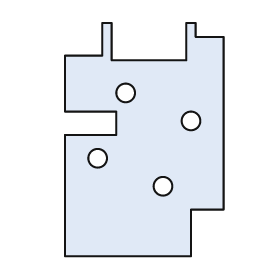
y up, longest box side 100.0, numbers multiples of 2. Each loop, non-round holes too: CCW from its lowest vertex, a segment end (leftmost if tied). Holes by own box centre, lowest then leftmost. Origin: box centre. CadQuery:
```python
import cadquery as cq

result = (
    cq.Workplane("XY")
    .moveTo(-34.0, -50.0)
    .lineTo(20.0, -50.0)
    .lineTo(20.0, -30.0)
    .lineTo(34.0, -30.0)
    .lineTo(34.0, 44.0)
    .lineTo(22.0, 44.0)
    .lineTo(22.0, 50.0)
    .lineTo(18.0, 50.0)
    .lineTo(18.0, 34.0)
    .lineTo(-14.0, 34.0)
    .lineTo(-14.0, 50.0)
    .lineTo(-18.0, 50.0)
    .lineTo(-18.0, 36.0)
    .lineTo(-34.0, 36.0)
    .lineTo(-34.0, 12.0)
    .lineTo(-12.0, 12.0)
    .lineTo(-12.0, 2.0)
    .lineTo(-34.0, 2.0)
    .close()
    .moveTo(8.0, -20.0)
    .circle(4.0)
    .moveTo(-20.0, -8.0)
    .circle(4.0)
    .moveTo(20.0, 8.0)
    .circle(4.0)
    .moveTo(-8.0, 20.0)
    .circle(4.0)
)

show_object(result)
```